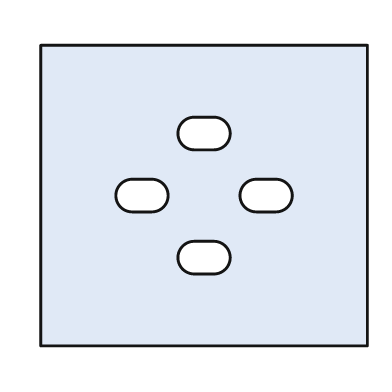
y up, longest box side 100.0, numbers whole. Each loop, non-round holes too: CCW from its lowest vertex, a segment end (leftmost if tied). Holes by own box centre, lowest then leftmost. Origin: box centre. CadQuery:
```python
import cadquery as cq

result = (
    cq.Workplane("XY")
    .moveTo(-50.0, -46.0)
    .lineTo(50.0, -46.0)
    .lineTo(50.0, 46.0)
    .lineTo(-50.0, 46.0)
    .close()
    .moveTo(-3.0, -24.0)
    .lineTo(3.0, -24.0)
    .threePointArc((8.0, -19.0), (3.0, -14.0))
    .lineTo(-3.0, -14.0)
    .threePointArc((-8.0, -19.0), (-3.0, -24.0))
    .close()
    .moveTo(-22.0, -5.0)
    .lineTo(-16.0, -5.0)
    .threePointArc((-11.0, 0.0), (-16.0, 5.0))
    .lineTo(-22.0, 5.0)
    .threePointArc((-27.0, 0.0), (-22.0, -5.0))
    .close()
    .moveTo(16.0, -5.0)
    .lineTo(22.0, -5.0)
    .threePointArc((27.0, 0.0), (22.0, 5.0))
    .lineTo(16.0, 5.0)
    .threePointArc((11.0, 0.0), (16.0, -5.0))
    .close()
    .moveTo(-3.0, 14.0)
    .lineTo(3.0, 14.0)
    .threePointArc((8.0, 19.0), (3.0, 24.0))
    .lineTo(-3.0, 24.0)
    .threePointArc((-8.0, 19.0), (-3.0, 14.0))
    .close()
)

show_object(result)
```